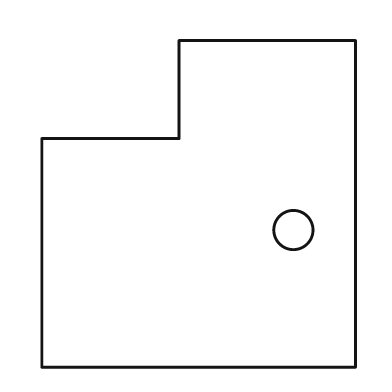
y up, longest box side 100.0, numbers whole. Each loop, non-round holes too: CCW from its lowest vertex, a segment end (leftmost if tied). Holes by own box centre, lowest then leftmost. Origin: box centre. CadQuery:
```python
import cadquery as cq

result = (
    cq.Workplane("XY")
    .moveTo(-48.0, -50.0)
    .lineTo(48.0, -50.0)
    .lineTo(48.0, 50.0)
    .lineTo(-6.0, 50.0)
    .lineTo(-6.0, 20.0)
    .lineTo(-48.0, 20.0)
    .close()
    .moveTo(29.0, -8.0)
    .circle(6.0)
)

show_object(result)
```